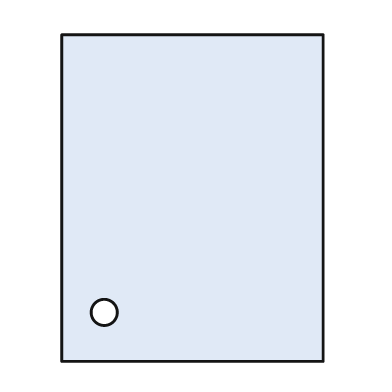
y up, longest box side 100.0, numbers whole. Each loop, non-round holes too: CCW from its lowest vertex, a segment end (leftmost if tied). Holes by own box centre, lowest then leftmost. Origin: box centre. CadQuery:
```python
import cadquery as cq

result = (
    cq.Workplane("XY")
    .moveTo(-40.0, -50.0)
    .lineTo(40.0, -50.0)
    .lineTo(40.0, 50.0)
    .lineTo(-40.0, 50.0)
    .close()
    .moveTo(-27.0, -35.0)
    .circle(4.0)
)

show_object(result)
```